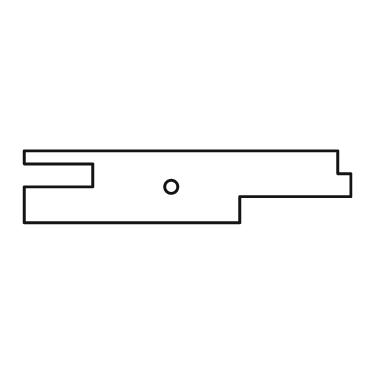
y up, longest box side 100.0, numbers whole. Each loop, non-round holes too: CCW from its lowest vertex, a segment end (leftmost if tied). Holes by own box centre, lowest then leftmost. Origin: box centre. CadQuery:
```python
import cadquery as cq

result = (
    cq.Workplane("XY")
    .moveTo(-50.0, -11.0)
    .lineTo(16.0, -11.0)
    .lineTo(16.0, -3.0)
    .lineTo(50.0, -3.0)
    .lineTo(50.0, 4.0)
    .lineTo(46.0, 4.0)
    .lineTo(46.0, 11.0)
    .lineTo(-50.0, 11.0)
    .lineTo(-50.0, 7.0)
    .lineTo(-29.0, 7.0)
    .lineTo(-29.0, 0.0)
    .lineTo(-50.0, 0.0)
    .close()
    .moveTo(-5.0, 0.0)
    .circle(2.0)
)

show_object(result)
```